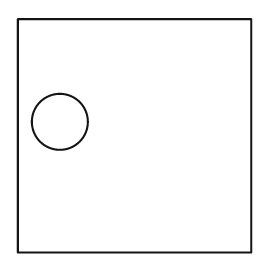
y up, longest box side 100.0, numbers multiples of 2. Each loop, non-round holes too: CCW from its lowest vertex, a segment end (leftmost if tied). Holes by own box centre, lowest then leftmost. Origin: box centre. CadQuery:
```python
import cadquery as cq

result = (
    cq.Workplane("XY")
    .moveTo(-50.0, -50.0)
    .lineTo(50.0, -50.0)
    .lineTo(50.0, 50.0)
    .lineTo(-50.0, 50.0)
    .close()
    .moveTo(-32.0, 6.0)
    .circle(12.0)
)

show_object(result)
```